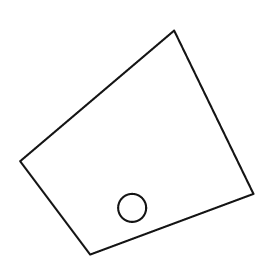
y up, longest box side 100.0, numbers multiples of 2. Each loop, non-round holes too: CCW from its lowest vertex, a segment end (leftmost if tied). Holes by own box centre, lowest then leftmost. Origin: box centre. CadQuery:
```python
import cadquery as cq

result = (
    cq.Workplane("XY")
    .moveTo(-20.0, -48.0)
    .lineTo(50.0, -22.0)
    .lineTo(16.0, 48.0)
    .lineTo(-50.0, -8.0)
    .close()
    .moveTo(-2.0, -28.0)
    .circle(6.0)
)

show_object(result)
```